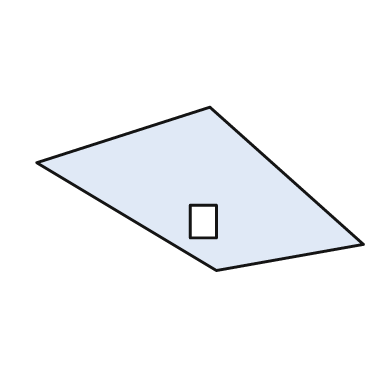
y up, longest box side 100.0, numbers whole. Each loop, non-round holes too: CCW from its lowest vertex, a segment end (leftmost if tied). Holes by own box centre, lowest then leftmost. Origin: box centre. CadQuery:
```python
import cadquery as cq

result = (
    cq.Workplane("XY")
    .moveTo(5.0, -25.0)
    .lineTo(50.0, -17.0)
    .lineTo(3.0, 25.0)
    .lineTo(-50.0, 8.0)
    .close()
    .moveTo(-3.0, -15.0)
    .lineTo(5.0, -15.0)
    .lineTo(5.0, -5.0)
    .lineTo(-3.0, -5.0)
    .close()
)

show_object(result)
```